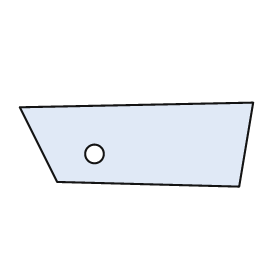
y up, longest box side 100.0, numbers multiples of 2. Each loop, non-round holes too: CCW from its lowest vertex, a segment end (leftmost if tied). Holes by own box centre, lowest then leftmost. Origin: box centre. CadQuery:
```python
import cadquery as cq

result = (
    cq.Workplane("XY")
    .moveTo(44.0, -18.0)
    .lineTo(50.0, 18.0)
    .lineTo(-50.0, 16.0)
    .lineTo(-34.0, -16.0)
    .close()
    .moveTo(-18.0, -4.0)
    .circle(4.0)
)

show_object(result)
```